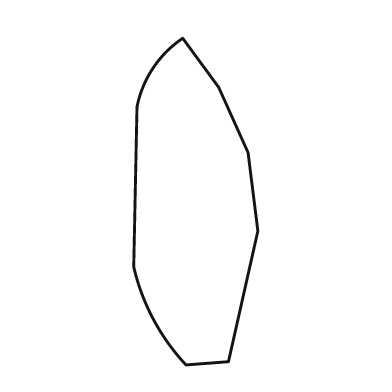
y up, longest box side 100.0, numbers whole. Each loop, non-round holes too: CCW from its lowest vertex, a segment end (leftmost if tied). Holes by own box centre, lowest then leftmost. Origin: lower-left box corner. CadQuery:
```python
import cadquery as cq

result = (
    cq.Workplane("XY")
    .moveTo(16.0, 0.0)
    .lineTo(29.0, 1.0)
    .lineTo(38.0, 41.0)
    .lineTo(35.0, 65.0)
    .lineTo(26.0, 85.0)
    .lineTo(15.0, 100.0)
    .threePointArc((6.0, 91.0), (1.0, 79.0))
    .lineTo(0.0, 30.0)
    .threePointArc((6.0, 14.0), (16.0, 0.0))
    .close()
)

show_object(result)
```